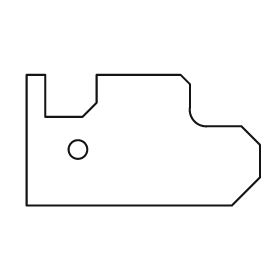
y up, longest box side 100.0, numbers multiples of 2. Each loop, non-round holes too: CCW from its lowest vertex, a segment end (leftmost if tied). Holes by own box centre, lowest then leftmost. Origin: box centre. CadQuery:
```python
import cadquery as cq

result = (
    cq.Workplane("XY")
    .moveTo(-50.0, -28.0)
    .lineTo(38.0, -28.0)
    .lineTo(50.0, -16.0)
    .lineTo(50.0, -2.0)
    .lineTo(42.0, 6.0)
    .lineTo(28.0, 6.0)
    .threePointArc((22.0, 8.0), (20.0, 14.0))
    .lineTo(20.0, 24.0)
    .lineTo(16.0, 28.0)
    .lineTo(-20.0, 28.0)
    .lineTo(-20.0, 16.0)
    .lineTo(-26.0, 10.0)
    .lineTo(-42.0, 10.0)
    .lineTo(-42.0, 28.0)
    .lineTo(-50.0, 28.0)
    .close()
    .moveTo(-28.0, -4.0)
    .circle(4.0)
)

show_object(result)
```